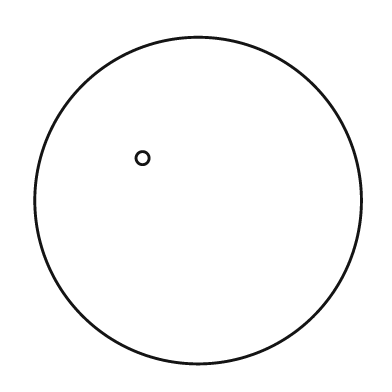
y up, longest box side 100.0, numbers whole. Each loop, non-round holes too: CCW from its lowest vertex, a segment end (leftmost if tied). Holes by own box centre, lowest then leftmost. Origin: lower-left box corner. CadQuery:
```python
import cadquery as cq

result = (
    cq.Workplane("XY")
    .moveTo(50.0, 50.0)
    .circle(50.0)
    .moveTo(33.0, 63.0)
    .circle(2.0)
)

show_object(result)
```